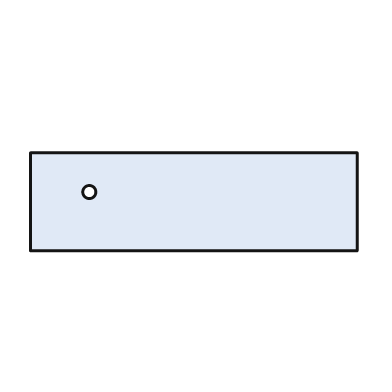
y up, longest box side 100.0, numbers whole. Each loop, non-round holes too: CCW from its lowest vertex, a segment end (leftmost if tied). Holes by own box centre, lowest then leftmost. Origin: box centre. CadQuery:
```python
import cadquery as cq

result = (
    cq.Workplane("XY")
    .moveTo(-50.0, -15.0)
    .lineTo(50.0, -15.0)
    .lineTo(50.0, 15.0)
    .lineTo(-50.0, 15.0)
    .close()
    .moveTo(-32.0, 3.0)
    .circle(2.0)
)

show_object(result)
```